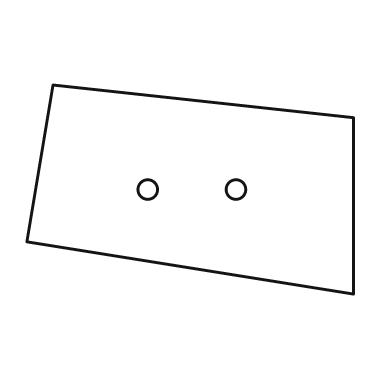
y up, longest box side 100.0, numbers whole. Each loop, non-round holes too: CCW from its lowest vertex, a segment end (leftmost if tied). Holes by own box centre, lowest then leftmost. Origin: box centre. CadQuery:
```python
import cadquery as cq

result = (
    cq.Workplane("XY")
    .moveTo(50.0, -32.0)
    .lineTo(50.0, 22.0)
    .lineTo(-42.0, 32.0)
    .lineTo(-50.0, -16.0)
    .close()
    .moveTo(-13.0, 0.0)
    .circle(3.0)
    .moveTo(14.0, 0.0)
    .circle(3.0)
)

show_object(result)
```